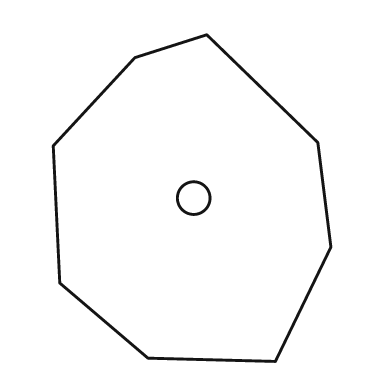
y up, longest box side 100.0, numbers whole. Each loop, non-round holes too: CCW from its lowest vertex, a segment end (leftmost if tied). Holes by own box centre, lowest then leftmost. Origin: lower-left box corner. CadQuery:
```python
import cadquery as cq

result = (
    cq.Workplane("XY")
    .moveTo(68.0, 0.0)
    .lineTo(85.0, 35.0)
    .lineTo(81.0, 67.0)
    .lineTo(47.0, 100.0)
    .lineTo(25.0, 93.0)
    .lineTo(0.0, 66.0)
    .lineTo(2.0, 24.0)
    .lineTo(29.0, 1.0)
    .close()
    .moveTo(43.0, 50.0)
    .circle(5.0)
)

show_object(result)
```